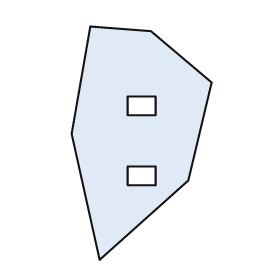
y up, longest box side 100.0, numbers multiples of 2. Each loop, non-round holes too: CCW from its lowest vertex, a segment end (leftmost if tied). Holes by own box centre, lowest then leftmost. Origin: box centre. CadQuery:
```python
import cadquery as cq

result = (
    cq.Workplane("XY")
    .moveTo(-18.0, -50.0)
    .lineTo(20.0, -16.0)
    .lineTo(30.0, 26.0)
    .lineTo(4.0, 48.0)
    .lineTo(-22.0, 50.0)
    .lineTo(-30.0, 4.0)
    .close()
    .moveTo(-6.0, -18.0)
    .lineTo(6.0, -18.0)
    .lineTo(6.0, -10.0)
    .lineTo(-6.0, -10.0)
    .close()
    .moveTo(-6.0, 12.0)
    .lineTo(6.0, 12.0)
    .lineTo(6.0, 20.0)
    .lineTo(-6.0, 20.0)
    .close()
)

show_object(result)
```